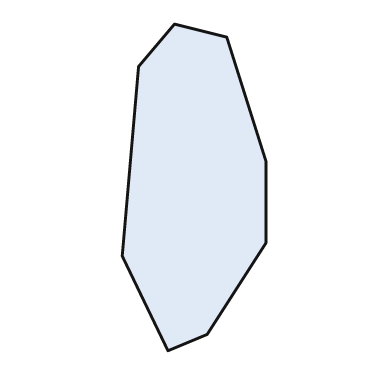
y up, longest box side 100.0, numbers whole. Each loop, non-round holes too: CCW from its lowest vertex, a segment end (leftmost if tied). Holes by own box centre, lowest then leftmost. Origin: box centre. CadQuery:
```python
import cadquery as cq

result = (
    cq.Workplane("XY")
    .moveTo(-8.0, -50.0)
    .lineTo(4.0, -45.0)
    .lineTo(22.0, -17.0)
    .lineTo(22.0, 8.0)
    .lineTo(10.0, 46.0)
    .lineTo(-6.0, 50.0)
    .lineTo(-17.0, 37.0)
    .lineTo(-22.0, -21.0)
    .close()
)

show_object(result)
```